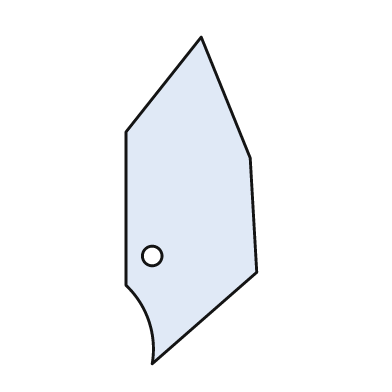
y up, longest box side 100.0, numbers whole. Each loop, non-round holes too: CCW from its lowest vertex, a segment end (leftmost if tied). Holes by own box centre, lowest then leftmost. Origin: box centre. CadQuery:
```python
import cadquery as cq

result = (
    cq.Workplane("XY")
    .moveTo(-12.0, -50.0)
    .lineTo(20.0, -22.0)
    .lineTo(18.0, 13.0)
    .lineTo(3.0, 50.0)
    .lineTo(-20.0, 21.0)
    .lineTo(-20.0, -26.0)
    .threePointArc((-13.0, -37.0), (-12.0, -50.0))
    .close()
    .moveTo(-12.0, -17.0)
    .circle(3.0)
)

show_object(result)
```